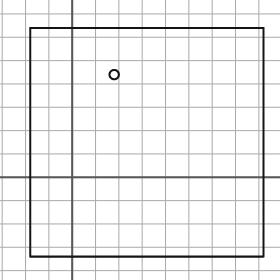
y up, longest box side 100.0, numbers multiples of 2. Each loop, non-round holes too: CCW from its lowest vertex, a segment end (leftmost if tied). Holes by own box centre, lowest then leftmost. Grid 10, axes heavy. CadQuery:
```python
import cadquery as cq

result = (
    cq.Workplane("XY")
    .moveTo(-18.0, -34.0)
    .lineTo(82.0, -34.0)
    .lineTo(82.0, 64.0)
    .lineTo(-18.0, 64.0)
    .close()
    .moveTo(18.0, 44.0)
    .circle(2.0)
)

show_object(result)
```